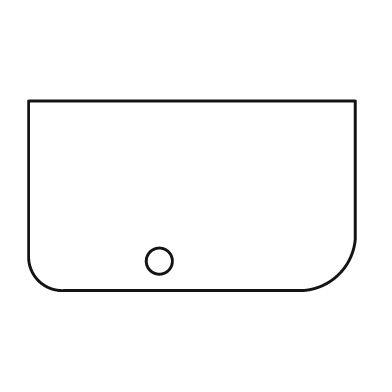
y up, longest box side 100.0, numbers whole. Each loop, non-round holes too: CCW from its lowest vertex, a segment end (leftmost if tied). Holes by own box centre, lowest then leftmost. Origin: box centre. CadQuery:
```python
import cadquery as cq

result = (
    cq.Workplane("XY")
    .moveTo(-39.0, -29.0)
    .lineTo(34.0, -29.0)
    .threePointArc((45.0, -24.0), (50.0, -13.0))
    .lineTo(50.0, 29.0)
    .lineTo(-50.0, 29.0)
    .lineTo(-50.0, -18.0)
    .threePointArc((-47.0, -26.0), (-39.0, -29.0))
    .close()
    .moveTo(-10.0, -20.0)
    .circle(4.0)
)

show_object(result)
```